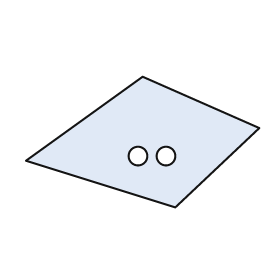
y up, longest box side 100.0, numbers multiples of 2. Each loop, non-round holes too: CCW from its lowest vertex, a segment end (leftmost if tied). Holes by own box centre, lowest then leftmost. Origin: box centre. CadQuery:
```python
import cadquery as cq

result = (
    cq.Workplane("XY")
    .moveTo(14.0, -28.0)
    .lineTo(50.0, 6.0)
    .lineTo(0.0, 28.0)
    .lineTo(-50.0, -8.0)
    .close()
    .moveTo(-2.0, -6.0)
    .circle(4.0)
    .moveTo(10.0, -6.0)
    .circle(4.0)
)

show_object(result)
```